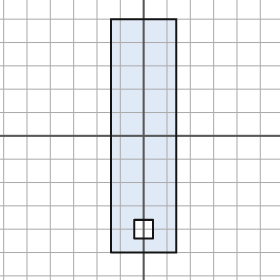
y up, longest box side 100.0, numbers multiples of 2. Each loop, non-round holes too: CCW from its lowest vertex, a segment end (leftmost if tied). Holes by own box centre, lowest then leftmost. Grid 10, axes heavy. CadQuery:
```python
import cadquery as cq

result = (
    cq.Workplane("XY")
    .moveTo(-14.0, -50.0)
    .lineTo(14.0, -50.0)
    .lineTo(14.0, 50.0)
    .lineTo(-14.0, 50.0)
    .close()
    .moveTo(-4.0, -44.0)
    .lineTo(4.0, -44.0)
    .lineTo(4.0, -36.0)
    .lineTo(-4.0, -36.0)
    .close()
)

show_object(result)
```